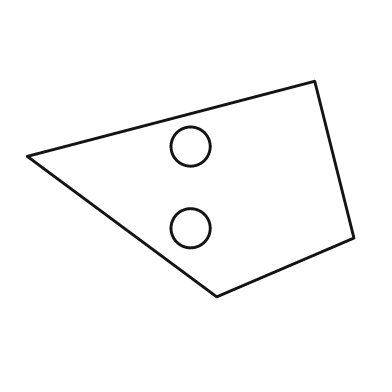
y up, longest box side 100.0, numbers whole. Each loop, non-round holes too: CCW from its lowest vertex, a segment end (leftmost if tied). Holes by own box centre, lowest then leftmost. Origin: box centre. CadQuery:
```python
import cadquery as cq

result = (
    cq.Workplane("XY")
    .moveTo(8.0, -33.0)
    .lineTo(50.0, -15.0)
    .lineTo(38.0, 33.0)
    .lineTo(-50.0, 10.0)
    .close()
    .moveTo(0.0, -12.0)
    .circle(6.0)
    .moveTo(0.0, 13.0)
    .circle(6.0)
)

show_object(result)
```